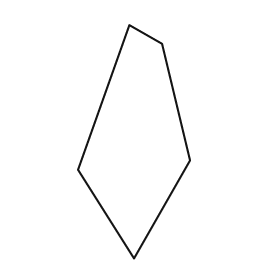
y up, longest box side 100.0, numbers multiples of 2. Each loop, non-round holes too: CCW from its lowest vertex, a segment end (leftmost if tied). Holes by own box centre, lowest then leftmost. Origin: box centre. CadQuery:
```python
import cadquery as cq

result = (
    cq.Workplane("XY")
    .moveTo(0.0, -50.0)
    .lineTo(24.0, -8.0)
    .lineTo(12.0, 42.0)
    .lineTo(-2.0, 50.0)
    .lineTo(-24.0, -12.0)
    .close()
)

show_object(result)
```